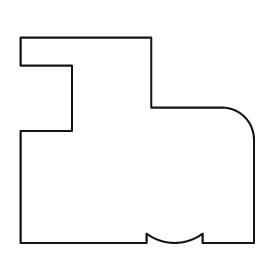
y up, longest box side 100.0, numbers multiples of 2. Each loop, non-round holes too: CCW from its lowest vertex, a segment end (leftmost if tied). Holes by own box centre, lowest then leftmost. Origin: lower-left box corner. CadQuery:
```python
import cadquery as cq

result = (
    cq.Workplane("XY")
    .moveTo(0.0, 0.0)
    .lineTo(54.0, 0.0)
    .lineTo(54.0, 4.0)
    .threePointArc((66.0, 0.0), (78.0, 4.0))
    .lineTo(78.0, 0.0)
    .lineTo(100.0, 0.0)
    .lineTo(100.0, 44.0)
    .threePointArc((96.0, 54.0), (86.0, 58.0))
    .lineTo(56.0, 58.0)
    .lineTo(56.0, 88.0)
    .lineTo(0.0, 88.0)
    .lineTo(0.0, 76.0)
    .lineTo(22.0, 76.0)
    .lineTo(22.0, 48.0)
    .lineTo(0.0, 48.0)
    .close()
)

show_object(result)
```